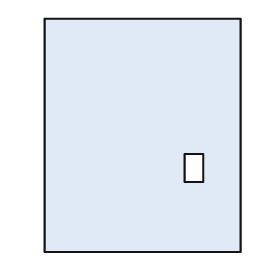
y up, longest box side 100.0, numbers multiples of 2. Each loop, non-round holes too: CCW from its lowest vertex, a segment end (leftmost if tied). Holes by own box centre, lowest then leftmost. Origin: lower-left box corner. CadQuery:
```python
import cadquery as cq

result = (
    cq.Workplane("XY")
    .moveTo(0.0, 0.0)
    .lineTo(84.0, 0.0)
    .lineTo(84.0, 100.0)
    .lineTo(0.0, 100.0)
    .close()
    .moveTo(60.0, 30.0)
    .lineTo(68.0, 30.0)
    .lineTo(68.0, 42.0)
    .lineTo(60.0, 42.0)
    .close()
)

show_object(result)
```